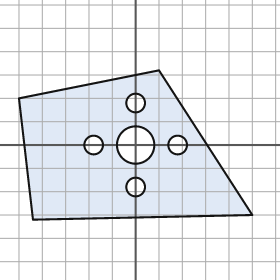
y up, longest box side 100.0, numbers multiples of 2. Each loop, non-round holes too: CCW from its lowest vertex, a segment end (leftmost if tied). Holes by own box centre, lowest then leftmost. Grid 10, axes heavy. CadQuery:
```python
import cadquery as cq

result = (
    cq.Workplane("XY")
    .moveTo(-44.0, -32.0)
    .lineTo(50.0, -30.0)
    .lineTo(10.0, 32.0)
    .lineTo(-50.0, 20.0)
    .close()
    .moveTo(0.0, -18.0)
    .circle(4.0)
    .moveTo(-18.0, 0.0)
    .circle(4.0)
    .moveTo(0.0, 0.0)
    .circle(8.0)
    .moveTo(18.0, 0.0)
    .circle(4.0)
    .moveTo(0.0, 18.0)
    .circle(4.0)
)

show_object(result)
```